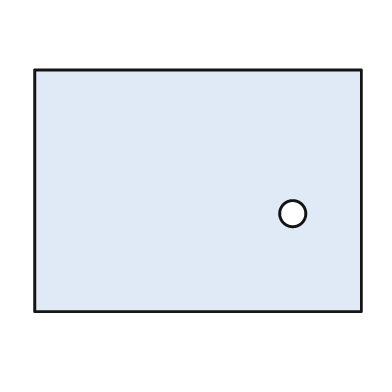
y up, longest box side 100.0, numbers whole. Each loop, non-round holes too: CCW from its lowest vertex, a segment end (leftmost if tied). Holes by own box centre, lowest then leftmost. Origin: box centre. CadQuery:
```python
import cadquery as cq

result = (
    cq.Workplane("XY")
    .moveTo(-50.0, -37.0)
    .lineTo(50.0, -37.0)
    .lineTo(50.0, 37.0)
    .lineTo(-50.0, 37.0)
    .close()
    .moveTo(29.0, -7.0)
    .circle(4.0)
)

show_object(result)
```